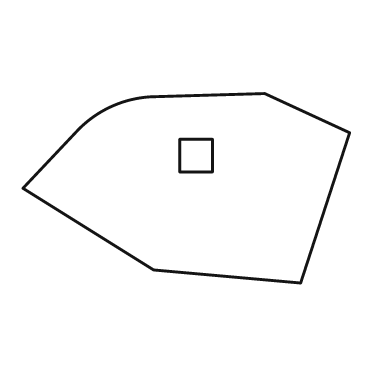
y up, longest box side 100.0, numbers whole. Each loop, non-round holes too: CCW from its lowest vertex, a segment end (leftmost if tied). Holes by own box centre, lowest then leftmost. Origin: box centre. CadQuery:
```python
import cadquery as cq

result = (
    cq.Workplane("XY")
    .moveTo(35.0, -29.0)
    .lineTo(50.0, 17.0)
    .lineTo(24.0, 29.0)
    .lineTo(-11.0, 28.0)
    .threePointArc((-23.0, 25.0), (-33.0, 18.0))
    .lineTo(-50.0, 0.0)
    .lineTo(-10.0, -25.0)
    .close()
    .moveTo(-2.0, 5.0)
    .lineTo(8.0, 5.0)
    .lineTo(8.0, 15.0)
    .lineTo(-2.0, 15.0)
    .close()
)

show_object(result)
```